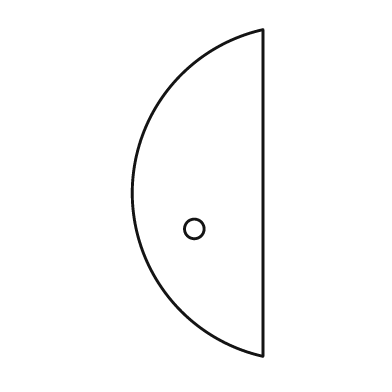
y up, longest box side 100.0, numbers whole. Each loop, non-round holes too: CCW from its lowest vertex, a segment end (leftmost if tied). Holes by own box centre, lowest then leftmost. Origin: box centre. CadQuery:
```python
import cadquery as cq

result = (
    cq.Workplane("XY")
    .moveTo(20.0, -50.0)
    .lineTo(20.0, 50.0)
    .threePointArc((-20.0, 0.0), (20.0, -50.0))
    .close()
    .moveTo(-1.0, -11.0)
    .circle(3.0)
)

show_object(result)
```